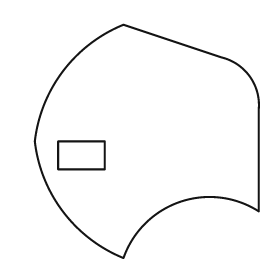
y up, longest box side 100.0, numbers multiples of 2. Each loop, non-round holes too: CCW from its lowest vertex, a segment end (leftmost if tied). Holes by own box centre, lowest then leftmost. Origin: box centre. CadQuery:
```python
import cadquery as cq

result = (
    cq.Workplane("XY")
    .moveTo(-10.0, -50.0)
    .threePointArc((14.0, -26.0), (48.0, -30.0))
    .lineTo(48.0, 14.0)
    .threePointArc((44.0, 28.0), (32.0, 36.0))
    .lineTo(-10.0, 50.0)
    .threePointArc((-36.0, 30.0), (-48.0, 0.0))
    .threePointArc((-36.0, -30.0), (-10.0, -50.0))
    .close()
    .moveTo(-38.0, -12.0)
    .lineTo(-18.0, -12.0)
    .lineTo(-18.0, 0.0)
    .lineTo(-38.0, 0.0)
    .close()
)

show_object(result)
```